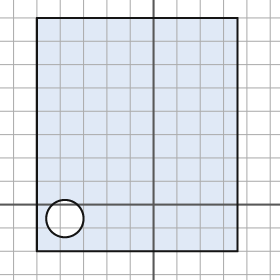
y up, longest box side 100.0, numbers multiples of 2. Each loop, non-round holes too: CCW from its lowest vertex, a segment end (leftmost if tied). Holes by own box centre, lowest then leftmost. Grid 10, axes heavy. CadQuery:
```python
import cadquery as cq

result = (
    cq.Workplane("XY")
    .moveTo(-50.0, -20.0)
    .lineTo(36.0, -20.0)
    .lineTo(36.0, 80.0)
    .lineTo(-50.0, 80.0)
    .close()
    .moveTo(-38.0, -6.0)
    .circle(8.0)
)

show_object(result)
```